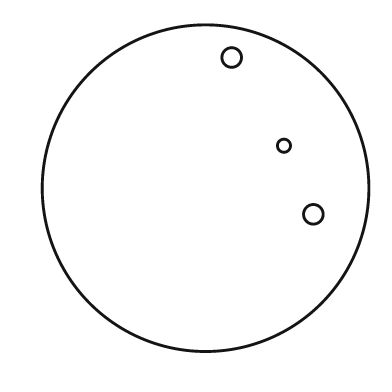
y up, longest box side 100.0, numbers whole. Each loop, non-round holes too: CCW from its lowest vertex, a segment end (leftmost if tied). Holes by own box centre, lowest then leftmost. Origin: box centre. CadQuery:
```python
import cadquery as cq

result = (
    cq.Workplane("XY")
    .moveTo(0.0, 0.0)
    .circle(50.0)
    .moveTo(33.0, -8.0)
    .circle(3.0)
    .moveTo(24.0, 13.0)
    .circle(2.0)
    .moveTo(8.0, 40.0)
    .circle(3.0)
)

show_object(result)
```